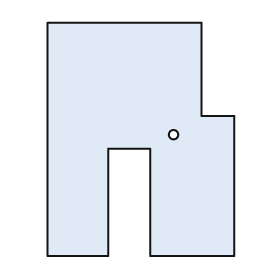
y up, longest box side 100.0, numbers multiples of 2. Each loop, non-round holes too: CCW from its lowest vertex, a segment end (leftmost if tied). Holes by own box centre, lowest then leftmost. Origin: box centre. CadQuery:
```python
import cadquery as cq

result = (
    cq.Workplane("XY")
    .moveTo(-40.0, -50.0)
    .lineTo(-14.0, -50.0)
    .lineTo(-14.0, -4.0)
    .lineTo(4.0, -4.0)
    .lineTo(4.0, -50.0)
    .lineTo(40.0, -50.0)
    .lineTo(40.0, 10.0)
    .lineTo(26.0, 10.0)
    .lineTo(26.0, 50.0)
    .lineTo(-40.0, 50.0)
    .close()
    .moveTo(14.0, 2.0)
    .circle(2.0)
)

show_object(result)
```